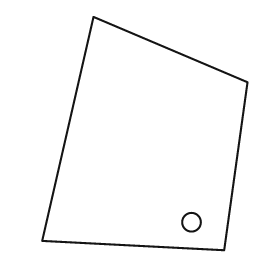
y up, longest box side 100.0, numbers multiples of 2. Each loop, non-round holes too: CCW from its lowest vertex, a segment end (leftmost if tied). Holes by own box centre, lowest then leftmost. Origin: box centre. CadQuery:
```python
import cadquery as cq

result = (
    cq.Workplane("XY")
    .moveTo(34.0, -50.0)
    .lineTo(44.0, 22.0)
    .lineTo(-22.0, 50.0)
    .lineTo(-44.0, -46.0)
    .close()
    .moveTo(20.0, -38.0)
    .circle(4.0)
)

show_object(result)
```